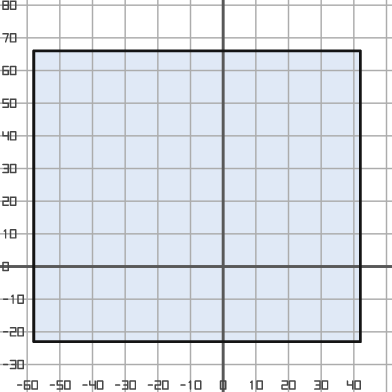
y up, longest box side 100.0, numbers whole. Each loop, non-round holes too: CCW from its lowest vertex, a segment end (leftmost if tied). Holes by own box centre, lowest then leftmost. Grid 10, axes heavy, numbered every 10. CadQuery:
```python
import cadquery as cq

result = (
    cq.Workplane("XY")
    .moveTo(-58.0, -23.0)
    .lineTo(42.0, -23.0)
    .lineTo(42.0, 66.0)
    .lineTo(-58.0, 66.0)
    .close()
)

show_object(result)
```